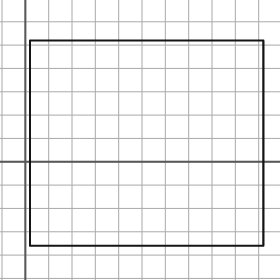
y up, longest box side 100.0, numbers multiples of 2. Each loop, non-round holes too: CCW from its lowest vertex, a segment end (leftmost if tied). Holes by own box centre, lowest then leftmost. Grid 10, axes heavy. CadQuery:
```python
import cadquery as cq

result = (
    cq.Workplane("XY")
    .moveTo(2.0, -36.0)
    .lineTo(102.0, -36.0)
    .lineTo(102.0, 52.0)
    .lineTo(2.0, 52.0)
    .close()
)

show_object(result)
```